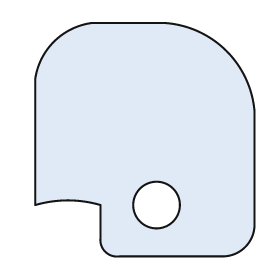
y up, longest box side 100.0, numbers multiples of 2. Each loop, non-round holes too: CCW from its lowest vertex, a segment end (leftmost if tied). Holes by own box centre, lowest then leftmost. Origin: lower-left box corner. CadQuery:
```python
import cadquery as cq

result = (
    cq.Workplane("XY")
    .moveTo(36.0, 0.0)
    .lineTo(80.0, 0.0)
    .threePointArc((90.0, 4.0), (94.0, 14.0))
    .lineTo(94.0, 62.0)
    .threePointArc((82.0, 88.0), (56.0, 100.0))
    .lineTo(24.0, 100.0)
    .threePointArc((8.0, 92.0), (0.0, 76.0))
    .lineTo(0.0, 22.0)
    .threePointArc((14.0, 24.0), (28.0, 22.0))
    .lineTo(28.0, 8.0)
    .threePointArc((30.0, 2.0), (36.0, 0.0))
    .close()
    .moveTo(52.0, 22.0)
    .circle(10.0)
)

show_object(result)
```